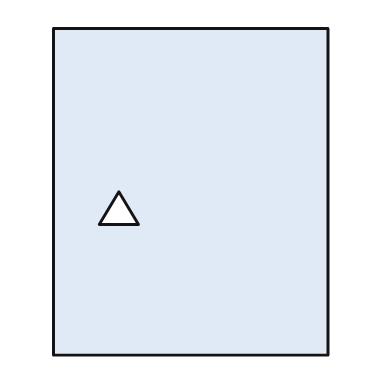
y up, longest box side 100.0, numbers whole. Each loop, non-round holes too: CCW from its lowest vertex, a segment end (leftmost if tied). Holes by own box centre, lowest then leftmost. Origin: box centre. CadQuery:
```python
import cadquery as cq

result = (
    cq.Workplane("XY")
    .moveTo(-42.0, -50.0)
    .lineTo(42.0, -50.0)
    .lineTo(42.0, 50.0)
    .lineTo(-42.0, 50.0)
    .close()
    .moveTo(-28.0, -10.0)
    .lineTo(-16.0, -10.0)
    .lineTo(-22.0, 0.0)
    .close()
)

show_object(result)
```